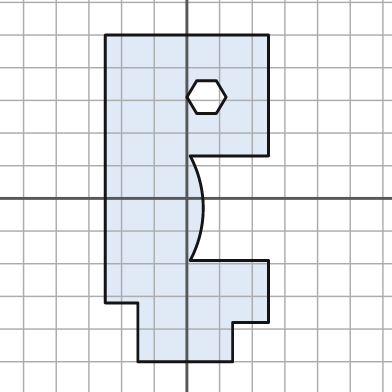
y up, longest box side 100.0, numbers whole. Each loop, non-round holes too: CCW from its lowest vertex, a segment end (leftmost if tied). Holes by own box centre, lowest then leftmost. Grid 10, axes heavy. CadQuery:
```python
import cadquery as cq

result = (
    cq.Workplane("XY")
    .moveTo(-15.0, -50.0)
    .lineTo(14.0, -50.0)
    .lineTo(14.0, -38.0)
    .lineTo(25.0, -38.0)
    .lineTo(25.0, -19.0)
    .lineTo(1.0, -19.0)
    .threePointArc((5.0, -3.0), (1.0, 13.0))
    .lineTo(25.0, 13.0)
    .lineTo(25.0, 50.0)
    .lineTo(-25.0, 50.0)
    .lineTo(-25.0, -32.0)
    .lineTo(-15.0, -32.0)
    .close()
    .moveTo(3.0, 26.0)
    .lineTo(9.0, 26.0)
    .lineTo(12.0, 31.0)
    .lineTo(9.0, 36.0)
    .lineTo(3.0, 36.0)
    .lineTo(0.0, 31.0)
    .close()
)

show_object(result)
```